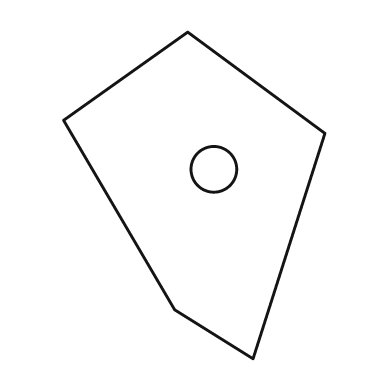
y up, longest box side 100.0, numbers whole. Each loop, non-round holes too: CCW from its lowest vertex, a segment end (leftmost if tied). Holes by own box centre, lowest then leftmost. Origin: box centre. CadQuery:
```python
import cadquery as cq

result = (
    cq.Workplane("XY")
    .moveTo(18.0, -50.0)
    .lineTo(40.0, 19.0)
    .lineTo(-2.0, 50.0)
    .lineTo(-40.0, 23.0)
    .lineTo(-6.0, -35.0)
    .close()
    .moveTo(6.0, 8.0)
    .circle(7.0)
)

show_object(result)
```